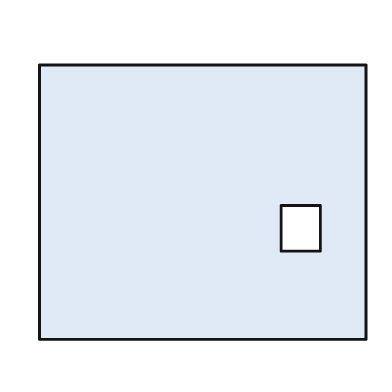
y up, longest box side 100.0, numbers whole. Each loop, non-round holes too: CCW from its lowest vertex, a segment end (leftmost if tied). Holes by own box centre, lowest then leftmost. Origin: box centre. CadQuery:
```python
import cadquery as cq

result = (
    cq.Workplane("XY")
    .moveTo(-50.0, -42.0)
    .lineTo(50.0, -42.0)
    .lineTo(50.0, 42.0)
    .lineTo(-50.0, 42.0)
    .close()
    .moveTo(24.0, -15.0)
    .lineTo(36.0, -15.0)
    .lineTo(36.0, -1.0)
    .lineTo(24.0, -1.0)
    .close()
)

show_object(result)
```